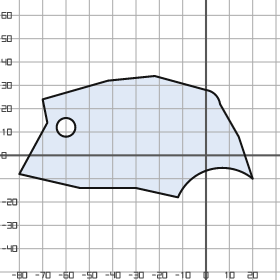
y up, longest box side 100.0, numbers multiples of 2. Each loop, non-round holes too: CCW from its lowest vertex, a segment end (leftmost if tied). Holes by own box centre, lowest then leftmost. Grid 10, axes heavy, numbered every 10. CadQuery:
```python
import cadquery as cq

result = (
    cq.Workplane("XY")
    .moveTo(-12.0, -18.0)
    .threePointArc((2.0, -6.0), (20.0, -10.0))
    .lineTo(14.0, 8.0)
    .lineTo(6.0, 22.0)
    .threePointArc((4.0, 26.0), (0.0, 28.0))
    .lineTo(-22.0, 34.0)
    .lineTo(-42.0, 32.0)
    .lineTo(-70.0, 24.0)
    .lineTo(-68.0, 14.0)
    .lineTo(-80.0, -8.0)
    .lineTo(-54.0, -14.0)
    .lineTo(-30.0, -14.0)
    .close()
    .moveTo(-60.0, 12.0)
    .circle(4.0)
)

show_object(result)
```